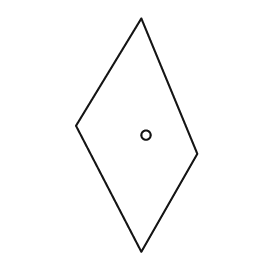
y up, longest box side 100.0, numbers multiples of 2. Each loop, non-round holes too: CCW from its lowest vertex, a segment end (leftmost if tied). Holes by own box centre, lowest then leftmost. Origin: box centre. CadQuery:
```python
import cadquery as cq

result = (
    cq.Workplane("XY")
    .moveTo(2.0, -50.0)
    .lineTo(26.0, -8.0)
    .lineTo(2.0, 50.0)
    .lineTo(-26.0, 4.0)
    .close()
    .moveTo(4.0, 0.0)
    .circle(2.0)
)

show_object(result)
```